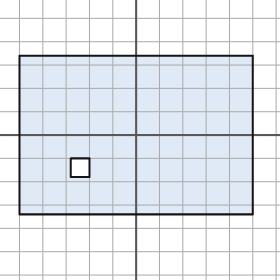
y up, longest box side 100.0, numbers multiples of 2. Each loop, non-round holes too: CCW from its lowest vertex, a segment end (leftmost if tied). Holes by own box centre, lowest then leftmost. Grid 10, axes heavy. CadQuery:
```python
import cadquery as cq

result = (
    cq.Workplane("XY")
    .moveTo(-50.0, -34.0)
    .lineTo(50.0, -34.0)
    .lineTo(50.0, 34.0)
    .lineTo(-50.0, 34.0)
    .close()
    .moveTo(-28.0, -18.0)
    .lineTo(-20.0, -18.0)
    .lineTo(-20.0, -10.0)
    .lineTo(-28.0, -10.0)
    .close()
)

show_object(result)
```